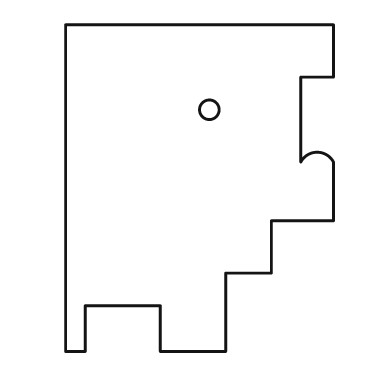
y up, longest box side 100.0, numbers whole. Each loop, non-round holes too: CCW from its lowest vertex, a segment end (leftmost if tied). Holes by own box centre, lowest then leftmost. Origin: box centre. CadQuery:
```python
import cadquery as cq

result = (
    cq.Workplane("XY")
    .moveTo(-41.0, -50.0)
    .lineTo(-35.0, -50.0)
    .lineTo(-35.0, -36.0)
    .lineTo(-12.0, -36.0)
    .lineTo(-12.0, -50.0)
    .lineTo(8.0, -50.0)
    .lineTo(8.0, -26.0)
    .lineTo(22.0, -26.0)
    .lineTo(22.0, -10.0)
    .lineTo(41.0, -10.0)
    .lineTo(41.0, 8.0)
    .threePointArc((36.0, 11.0), (31.0, 8.0))
    .lineTo(31.0, 34.0)
    .lineTo(41.0, 34.0)
    .lineTo(41.0, 50.0)
    .lineTo(-41.0, 50.0)
    .close()
    .moveTo(3.0, 24.0)
    .circle(3.0)
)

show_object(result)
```